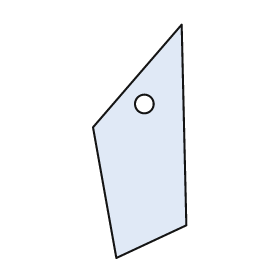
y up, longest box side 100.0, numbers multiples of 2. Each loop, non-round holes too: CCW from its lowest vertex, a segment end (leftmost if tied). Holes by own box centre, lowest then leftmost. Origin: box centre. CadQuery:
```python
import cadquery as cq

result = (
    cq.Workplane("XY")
    .moveTo(-10.0, -50.0)
    .lineTo(20.0, -36.0)
    .lineTo(18.0, 50.0)
    .lineTo(-20.0, 6.0)
    .close()
    .moveTo(2.0, 16.0)
    .circle(4.0)
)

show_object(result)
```